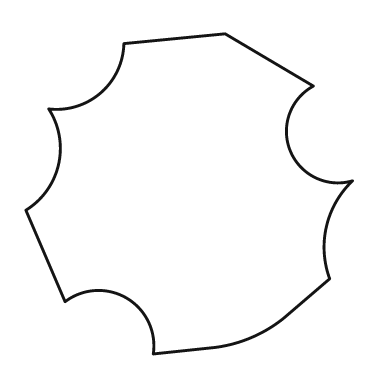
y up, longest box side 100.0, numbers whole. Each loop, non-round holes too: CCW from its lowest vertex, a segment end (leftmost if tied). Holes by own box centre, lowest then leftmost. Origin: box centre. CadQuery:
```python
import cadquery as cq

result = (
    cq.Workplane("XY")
    .moveTo(-11.0, -49.0)
    .lineTo(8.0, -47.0)
    .threePointArc((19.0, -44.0), (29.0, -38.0))
    .lineTo(43.0, -26.0)
    .threePointArc((42.0, -10.0), (50.0, 4.0))
    .threePointArc((31.0, 13.0), (38.0, 33.0))
    .lineTo(11.0, 49.0)
    .lineTo(-20.0, 46.0)
    .threePointArc((-27.0, 31.0), (-43.0, 26.0))
    .threePointArc((-40.0, 9.0), (-50.0, -5.0))
    .lineTo(-38.0, -33.0)
    .threePointArc((-19.0, -32.0), (-11.0, -49.0))
    .close()
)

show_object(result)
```